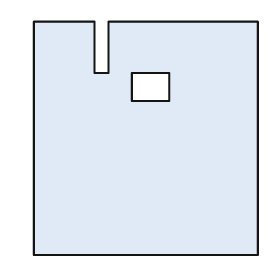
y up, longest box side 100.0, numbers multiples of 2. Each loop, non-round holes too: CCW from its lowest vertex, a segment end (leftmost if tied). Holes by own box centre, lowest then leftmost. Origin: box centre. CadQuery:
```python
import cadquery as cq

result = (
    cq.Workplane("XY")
    .moveTo(-48.0, -50.0)
    .lineTo(48.0, -50.0)
    .lineTo(48.0, 50.0)
    .lineTo(-16.0, 50.0)
    .lineTo(-16.0, 28.0)
    .lineTo(-22.0, 28.0)
    .lineTo(-22.0, 50.0)
    .lineTo(-48.0, 50.0)
    .close()
    .moveTo(-6.0, 16.0)
    .lineTo(10.0, 16.0)
    .lineTo(10.0, 28.0)
    .lineTo(-6.0, 28.0)
    .close()
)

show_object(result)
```